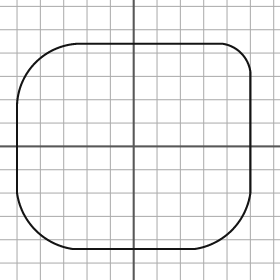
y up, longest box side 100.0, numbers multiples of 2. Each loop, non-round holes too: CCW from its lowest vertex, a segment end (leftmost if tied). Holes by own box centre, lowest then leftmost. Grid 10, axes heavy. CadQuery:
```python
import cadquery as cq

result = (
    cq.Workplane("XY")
    .moveTo(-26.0, -44.0)
    .lineTo(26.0, -44.0)
    .threePointArc((42.0, -36.0), (50.0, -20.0))
    .lineTo(50.0, 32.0)
    .threePointArc((46.0, 40.0), (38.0, 44.0))
    .lineTo(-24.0, 44.0)
    .threePointArc((-42.0, 36.0), (-50.0, 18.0))
    .lineTo(-50.0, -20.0)
    .threePointArc((-42.0, -36.0), (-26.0, -44.0))
    .close()
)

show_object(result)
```